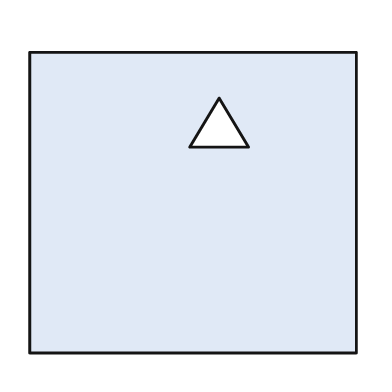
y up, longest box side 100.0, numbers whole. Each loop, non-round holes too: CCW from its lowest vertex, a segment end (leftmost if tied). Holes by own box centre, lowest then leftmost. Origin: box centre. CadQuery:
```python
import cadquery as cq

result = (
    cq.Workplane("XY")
    .moveTo(-50.0, -46.0)
    .lineTo(50.0, -46.0)
    .lineTo(50.0, 46.0)
    .lineTo(-50.0, 46.0)
    .close()
    .moveTo(-1.0, 17.0)
    .lineTo(17.0, 17.0)
    .lineTo(8.0, 32.0)
    .close()
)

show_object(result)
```